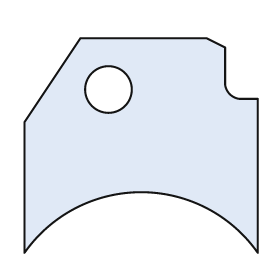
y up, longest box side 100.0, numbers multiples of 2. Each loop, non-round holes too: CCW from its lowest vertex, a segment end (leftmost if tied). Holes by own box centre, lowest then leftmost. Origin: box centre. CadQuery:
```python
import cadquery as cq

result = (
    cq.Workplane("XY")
    .moveTo(-50.0, -46.0)
    .threePointArc((0.0, -20.0), (50.0, -46.0))
    .lineTo(50.0, 20.0)
    .lineTo(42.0, 20.0)
    .threePointArc((38.0, 22.0), (36.0, 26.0))
    .lineTo(36.0, 42.0)
    .lineTo(28.0, 46.0)
    .lineTo(-26.0, 46.0)
    .lineTo(-50.0, 10.0)
    .close()
    .moveTo(-14.0, 24.0)
    .circle(10.0)
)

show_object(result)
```